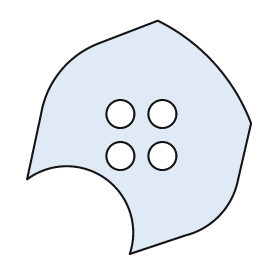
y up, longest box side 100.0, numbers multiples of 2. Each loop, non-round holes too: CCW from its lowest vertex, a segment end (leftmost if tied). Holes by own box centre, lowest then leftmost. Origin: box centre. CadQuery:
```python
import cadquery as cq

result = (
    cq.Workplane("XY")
    .moveTo(-4.0, -50.0)
    .lineTo(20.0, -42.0)
    .threePointArc((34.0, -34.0), (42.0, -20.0))
    .lineTo(48.0, 6.0)
    .threePointArc((32.0, 32.0), (8.0, 50.0))
    .lineTo(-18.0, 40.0)
    .threePointArc((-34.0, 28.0), (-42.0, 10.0))
    .lineTo(-48.0, -18.0)
    .threePointArc((-14.0, -18.0), (-4.0, -50.0))
    .close()
    .moveTo(-8.0, -8.0)
    .circle(6.0)
    .moveTo(10.0, -8.0)
    .circle(6.0)
    .moveTo(-8.0, 10.0)
    .circle(6.0)
    .moveTo(10.0, 10.0)
    .circle(6.0)
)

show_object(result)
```